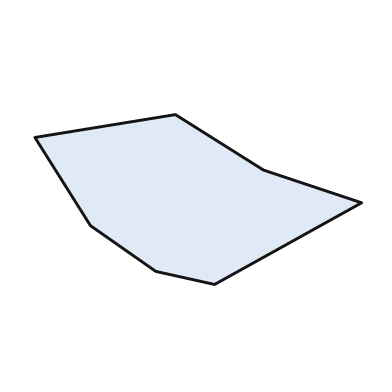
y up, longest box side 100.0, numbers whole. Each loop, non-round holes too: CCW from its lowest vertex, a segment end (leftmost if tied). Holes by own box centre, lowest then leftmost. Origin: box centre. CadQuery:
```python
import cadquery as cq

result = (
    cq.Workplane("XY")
    .moveTo(5.0, -26.0)
    .lineTo(50.0, -1.0)
    .lineTo(20.0, 9.0)
    .lineTo(-7.0, 26.0)
    .lineTo(-50.0, 19.0)
    .lineTo(-33.0, -8.0)
    .lineTo(-13.0, -22.0)
    .close()
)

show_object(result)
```